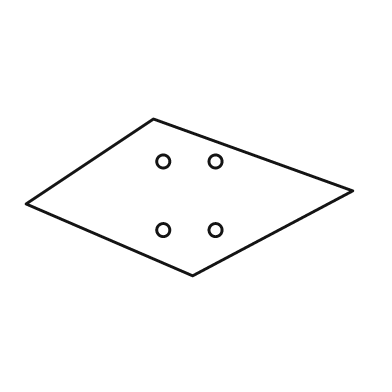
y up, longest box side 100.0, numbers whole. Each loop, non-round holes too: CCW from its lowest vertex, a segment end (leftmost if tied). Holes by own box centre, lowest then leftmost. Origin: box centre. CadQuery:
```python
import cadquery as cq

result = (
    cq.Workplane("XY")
    .moveTo(1.0, -24.0)
    .lineTo(50.0, 2.0)
    .lineTo(-11.0, 24.0)
    .lineTo(-50.0, -2.0)
    .close()
    .moveTo(-8.0, -10.0)
    .circle(2.0)
    .moveTo(8.0, -10.0)
    .circle(2.0)
    .moveTo(-8.0, 11.0)
    .circle(2.0)
    .moveTo(8.0, 11.0)
    .circle(2.0)
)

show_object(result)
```